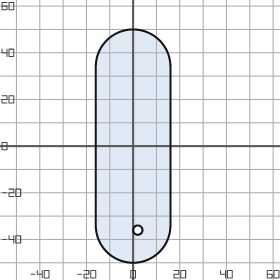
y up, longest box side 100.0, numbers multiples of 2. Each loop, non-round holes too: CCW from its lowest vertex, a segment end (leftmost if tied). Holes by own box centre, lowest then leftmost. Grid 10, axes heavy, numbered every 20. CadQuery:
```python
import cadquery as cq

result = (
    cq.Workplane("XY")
    .moveTo(-16.0, -34.0)
    .threePointArc((0.0, -50.0), (16.0, -34.0))
    .lineTo(16.0, 34.0)
    .threePointArc((0.0, 50.0), (-16.0, 34.0))
    .close()
    .moveTo(2.0, -36.0)
    .circle(2.0)
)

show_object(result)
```